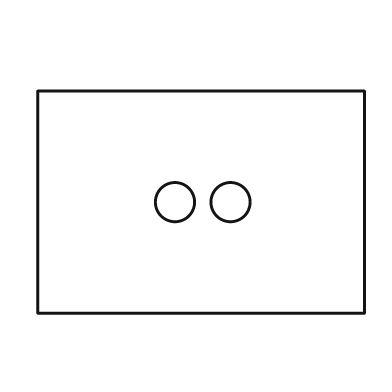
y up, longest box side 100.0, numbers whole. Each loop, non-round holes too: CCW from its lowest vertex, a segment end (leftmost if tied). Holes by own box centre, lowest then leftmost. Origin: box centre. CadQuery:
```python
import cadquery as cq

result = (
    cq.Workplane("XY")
    .moveTo(-50.0, -34.0)
    .lineTo(50.0, -34.0)
    .lineTo(50.0, 34.0)
    .lineTo(-50.0, 34.0)
    .close()
    .moveTo(-8.0, 0.0)
    .circle(6.0)
    .moveTo(9.0, 0.0)
    .circle(6.0)
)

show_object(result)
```